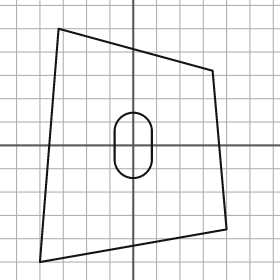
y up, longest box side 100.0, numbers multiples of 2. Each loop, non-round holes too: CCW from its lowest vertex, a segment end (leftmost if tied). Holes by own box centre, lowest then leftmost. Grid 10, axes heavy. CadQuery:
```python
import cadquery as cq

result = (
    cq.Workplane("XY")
    .moveTo(-40.0, -50.0)
    .lineTo(40.0, -36.0)
    .lineTo(34.0, 32.0)
    .lineTo(-32.0, 50.0)
    .close()
    .moveTo(-8.0, -6.0)
    .threePointArc((0.0, -14.0), (8.0, -6.0))
    .lineTo(8.0, 6.0)
    .threePointArc((0.0, 14.0), (-8.0, 6.0))
    .close()
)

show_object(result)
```